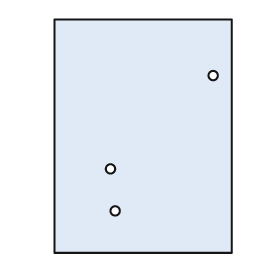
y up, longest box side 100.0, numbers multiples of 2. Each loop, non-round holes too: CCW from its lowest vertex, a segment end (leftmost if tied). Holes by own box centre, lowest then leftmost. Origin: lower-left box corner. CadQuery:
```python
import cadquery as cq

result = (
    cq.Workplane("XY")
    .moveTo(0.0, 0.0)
    .lineTo(76.0, 0.0)
    .lineTo(76.0, 100.0)
    .lineTo(0.0, 100.0)
    .close()
    .moveTo(26.0, 18.0)
    .circle(2.0)
    .moveTo(24.0, 36.0)
    .circle(2.0)
    .moveTo(68.0, 76.0)
    .circle(2.0)
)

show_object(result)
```